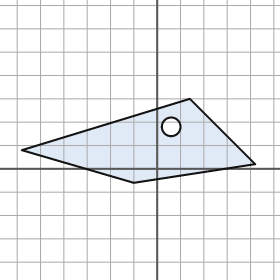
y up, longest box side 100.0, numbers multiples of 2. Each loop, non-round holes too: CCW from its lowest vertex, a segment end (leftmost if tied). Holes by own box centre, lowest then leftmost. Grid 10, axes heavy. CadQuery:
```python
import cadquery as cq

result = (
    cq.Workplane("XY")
    .moveTo(-10.0, -6.0)
    .lineTo(42.0, 2.0)
    .lineTo(14.0, 30.0)
    .lineTo(-58.0, 8.0)
    .close()
    .moveTo(6.0, 18.0)
    .circle(4.0)
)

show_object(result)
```